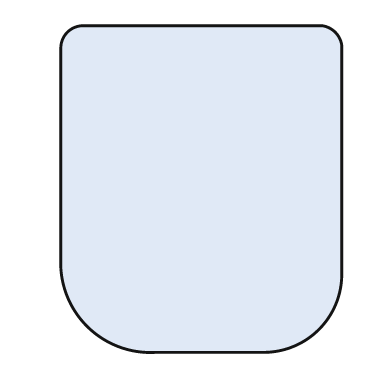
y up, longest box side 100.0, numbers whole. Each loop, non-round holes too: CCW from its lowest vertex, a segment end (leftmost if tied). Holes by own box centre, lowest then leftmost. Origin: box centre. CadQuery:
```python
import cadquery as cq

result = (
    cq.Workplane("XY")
    .moveTo(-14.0, -50.0)
    .lineTo(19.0, -50.0)
    .threePointArc((36.0, -43.0), (43.0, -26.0))
    .lineTo(43.0, 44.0)
    .threePointArc((41.0, 48.0), (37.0, 50.0))
    .lineTo(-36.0, 50.0)
    .threePointArc((-41.0, 48.0), (-43.0, 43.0))
    .lineTo(-43.0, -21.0)
    .threePointArc((-35.0, -42.0), (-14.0, -50.0))
    .close()
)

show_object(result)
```